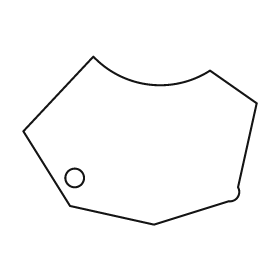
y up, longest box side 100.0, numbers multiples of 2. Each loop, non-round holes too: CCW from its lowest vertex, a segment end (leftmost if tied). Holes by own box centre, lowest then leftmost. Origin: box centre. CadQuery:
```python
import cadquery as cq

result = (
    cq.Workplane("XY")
    .moveTo(6.0, -36.0)
    .lineTo(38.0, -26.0)
    .threePointArc((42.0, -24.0), (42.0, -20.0))
    .lineTo(50.0, 16.0)
    .lineTo(30.0, 30.0)
    .threePointArc((4.0, 24.0), (-20.0, 36.0))
    .lineTo(-50.0, 4.0)
    .lineTo(-30.0, -28.0)
    .close()
    .moveTo(-28.0, -16.0)
    .circle(4.0)
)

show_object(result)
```